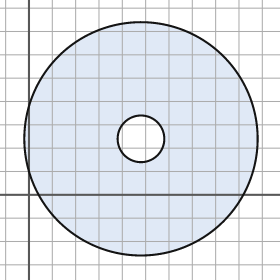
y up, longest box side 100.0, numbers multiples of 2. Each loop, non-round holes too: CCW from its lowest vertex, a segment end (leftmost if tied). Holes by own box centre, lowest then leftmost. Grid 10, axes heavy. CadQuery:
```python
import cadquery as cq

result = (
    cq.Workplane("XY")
    .moveTo(48.0, 24.0)
    .circle(50.0)
    .moveTo(48.0, 24.0)
    .circle(10.0)
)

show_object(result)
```